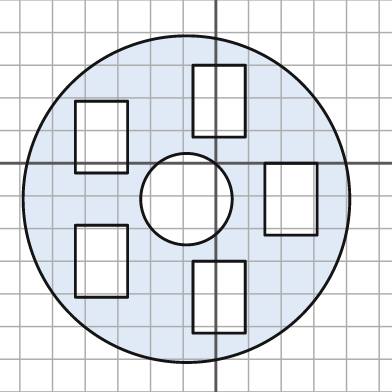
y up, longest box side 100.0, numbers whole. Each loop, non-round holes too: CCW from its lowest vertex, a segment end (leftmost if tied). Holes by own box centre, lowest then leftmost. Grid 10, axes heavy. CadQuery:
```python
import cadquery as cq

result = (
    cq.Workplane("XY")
    .moveTo(-9.0, -11.0)
    .circle(50.0)
    .moveTo(-7.0, -52.0)
    .lineTo(9.0, -52.0)
    .lineTo(9.0, -30.0)
    .lineTo(-7.0, -30.0)
    .close()
    .moveTo(-43.0, -41.0)
    .lineTo(-27.0, -41.0)
    .lineTo(-27.0, -19.0)
    .lineTo(-43.0, -19.0)
    .close()
    .moveTo(-9.0, -11.0)
    .circle(14.0)
    .moveTo(15.0, -22.0)
    .lineTo(31.0, -22.0)
    .lineTo(31.0, 0.0)
    .lineTo(15.0, 0.0)
    .close()
    .moveTo(-43.0, -3.0)
    .lineTo(-27.0, -3.0)
    .lineTo(-27.0, 19.0)
    .lineTo(-43.0, 19.0)
    .close()
    .moveTo(-7.0, 8.0)
    .lineTo(9.0, 8.0)
    .lineTo(9.0, 30.0)
    .lineTo(-7.0, 30.0)
    .close()
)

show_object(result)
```